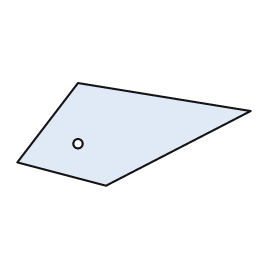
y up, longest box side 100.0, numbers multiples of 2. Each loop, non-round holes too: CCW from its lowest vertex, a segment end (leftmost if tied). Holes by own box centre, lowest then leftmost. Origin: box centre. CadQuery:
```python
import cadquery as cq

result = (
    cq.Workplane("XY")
    .moveTo(-12.0, -22.0)
    .lineTo(50.0, 10.0)
    .lineTo(-24.0, 22.0)
    .lineTo(-50.0, -12.0)
    .close()
    .moveTo(-24.0, -4.0)
    .circle(2.0)
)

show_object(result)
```